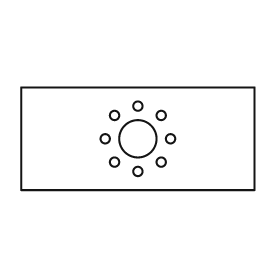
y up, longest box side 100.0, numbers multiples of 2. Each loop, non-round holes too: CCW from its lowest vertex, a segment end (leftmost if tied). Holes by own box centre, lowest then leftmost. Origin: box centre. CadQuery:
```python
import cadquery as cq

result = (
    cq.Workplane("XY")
    .moveTo(-50.0, -22.0)
    .lineTo(50.0, -22.0)
    .lineTo(50.0, 22.0)
    .lineTo(-50.0, 22.0)
    .close()
    .moveTo(0.0, -14.0)
    .circle(2.0)
    .moveTo(-10.0, -10.0)
    .circle(2.0)
    .moveTo(10.0, -10.0)
    .circle(2.0)
    .moveTo(-14.0, 0.0)
    .circle(2.0)
    .moveTo(0.0, 0.0)
    .circle(8.0)
    .moveTo(14.0, 0.0)
    .circle(2.0)
    .moveTo(-10.0, 10.0)
    .circle(2.0)
    .moveTo(10.0, 10.0)
    .circle(2.0)
    .moveTo(0.0, 14.0)
    .circle(2.0)
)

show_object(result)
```